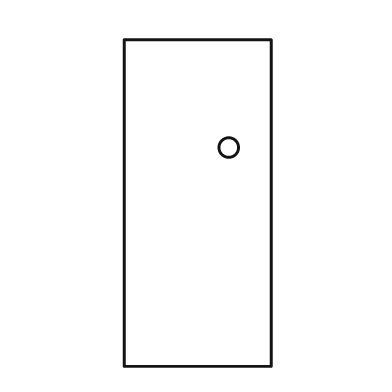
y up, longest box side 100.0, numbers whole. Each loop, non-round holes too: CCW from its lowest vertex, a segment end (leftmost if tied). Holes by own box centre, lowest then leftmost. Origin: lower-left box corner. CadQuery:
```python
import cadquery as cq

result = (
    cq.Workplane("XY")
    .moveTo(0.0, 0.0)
    .lineTo(45.0, 0.0)
    .lineTo(45.0, 100.0)
    .lineTo(0.0, 100.0)
    .close()
    .moveTo(32.0, 67.0)
    .circle(3.0)
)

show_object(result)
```